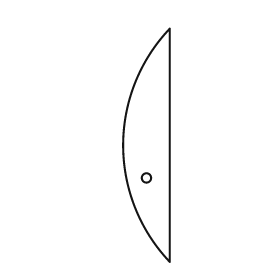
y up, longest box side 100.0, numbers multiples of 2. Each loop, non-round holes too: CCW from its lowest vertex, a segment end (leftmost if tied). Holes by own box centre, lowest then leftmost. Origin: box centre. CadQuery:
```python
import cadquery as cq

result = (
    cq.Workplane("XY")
    .moveTo(10.0, -50.0)
    .lineTo(10.0, 50.0)
    .threePointArc((-10.0, 0.0), (10.0, -50.0))
    .close()
    .moveTo(0.0, -14.0)
    .circle(2.0)
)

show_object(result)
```